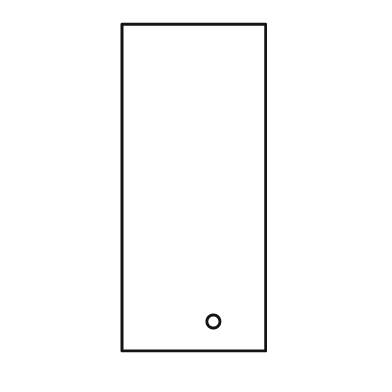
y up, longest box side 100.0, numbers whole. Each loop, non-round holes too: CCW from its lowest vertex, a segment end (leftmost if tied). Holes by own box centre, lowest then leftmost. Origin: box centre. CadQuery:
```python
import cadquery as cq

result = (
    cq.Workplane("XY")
    .moveTo(-22.0, -50.0)
    .lineTo(22.0, -50.0)
    .lineTo(22.0, 50.0)
    .lineTo(-22.0, 50.0)
    .close()
    .moveTo(6.0, -41.0)
    .circle(2.0)
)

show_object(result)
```